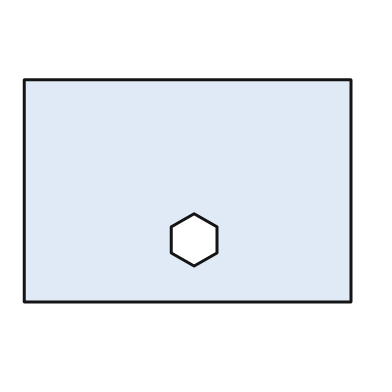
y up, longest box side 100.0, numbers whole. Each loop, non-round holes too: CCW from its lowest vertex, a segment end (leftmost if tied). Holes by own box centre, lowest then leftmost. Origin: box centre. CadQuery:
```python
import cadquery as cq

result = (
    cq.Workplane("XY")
    .moveTo(-50.0, -34.0)
    .lineTo(50.0, -34.0)
    .lineTo(50.0, 34.0)
    .lineTo(-50.0, 34.0)
    .close()
    .moveTo(2.0, -23.0)
    .lineTo(9.0, -19.0)
    .lineTo(9.0, -11.0)
    .lineTo(2.0, -7.0)
    .lineTo(-5.0, -11.0)
    .lineTo(-5.0, -19.0)
    .close()
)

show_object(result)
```